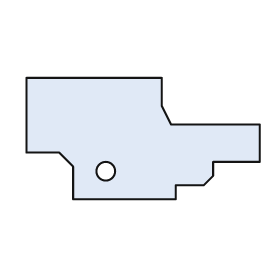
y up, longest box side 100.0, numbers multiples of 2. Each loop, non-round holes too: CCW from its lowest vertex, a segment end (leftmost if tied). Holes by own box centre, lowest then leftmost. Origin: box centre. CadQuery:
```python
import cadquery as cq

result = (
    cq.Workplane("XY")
    .moveTo(-30.0, -26.0)
    .lineTo(14.0, -26.0)
    .lineTo(14.0, -20.0)
    .lineTo(26.0, -20.0)
    .lineTo(30.0, -16.0)
    .lineTo(30.0, -10.0)
    .lineTo(50.0, -10.0)
    .lineTo(50.0, 6.0)
    .lineTo(12.0, 6.0)
    .lineTo(8.0, 14.0)
    .lineTo(8.0, 26.0)
    .lineTo(-50.0, 26.0)
    .lineTo(-50.0, -6.0)
    .lineTo(-36.0, -6.0)
    .lineTo(-30.0, -12.0)
    .close()
    .moveTo(-16.0, -14.0)
    .circle(4.0)
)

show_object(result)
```